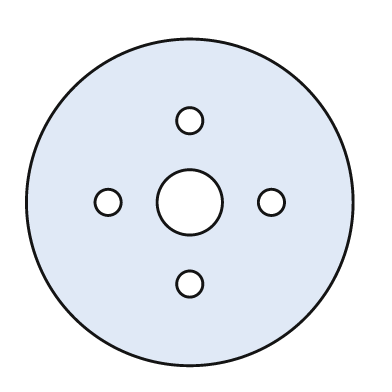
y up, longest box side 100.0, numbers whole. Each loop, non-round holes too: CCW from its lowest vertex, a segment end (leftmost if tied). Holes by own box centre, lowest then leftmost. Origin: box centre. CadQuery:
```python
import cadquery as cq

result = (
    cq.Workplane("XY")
    .moveTo(0.0, 0.0)
    .circle(50.0)
    .moveTo(0.0, -25.0)
    .circle(4.0)
    .moveTo(-25.0, 0.0)
    .circle(4.0)
    .moveTo(0.0, 0.0)
    .circle(10.0)
    .moveTo(25.0, 0.0)
    .circle(4.0)
    .moveTo(0.0, 25.0)
    .circle(4.0)
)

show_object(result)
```